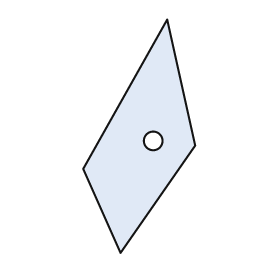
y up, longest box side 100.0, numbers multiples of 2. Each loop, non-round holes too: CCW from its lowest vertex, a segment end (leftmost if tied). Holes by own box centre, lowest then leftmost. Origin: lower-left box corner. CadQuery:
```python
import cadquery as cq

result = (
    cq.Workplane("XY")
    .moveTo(16.0, 0.0)
    .lineTo(48.0, 46.0)
    .lineTo(36.0, 100.0)
    .lineTo(0.0, 36.0)
    .close()
    .moveTo(30.0, 48.0)
    .circle(4.0)
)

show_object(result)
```